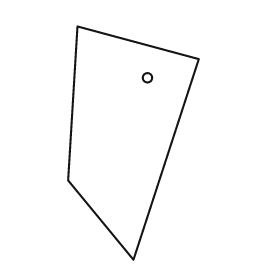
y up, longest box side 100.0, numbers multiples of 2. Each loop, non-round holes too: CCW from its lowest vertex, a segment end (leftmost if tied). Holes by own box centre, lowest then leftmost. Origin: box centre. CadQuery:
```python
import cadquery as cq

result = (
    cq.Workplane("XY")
    .moveTo(0.0, -50.0)
    .lineTo(28.0, 36.0)
    .lineTo(-24.0, 50.0)
    .lineTo(-28.0, -16.0)
    .close()
    .moveTo(6.0, 28.0)
    .circle(2.0)
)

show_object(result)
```